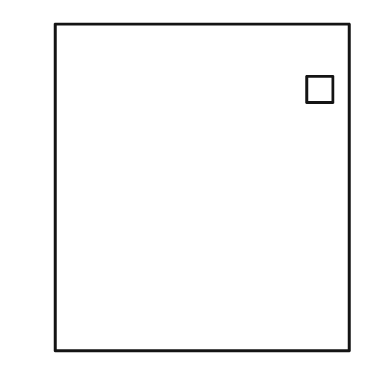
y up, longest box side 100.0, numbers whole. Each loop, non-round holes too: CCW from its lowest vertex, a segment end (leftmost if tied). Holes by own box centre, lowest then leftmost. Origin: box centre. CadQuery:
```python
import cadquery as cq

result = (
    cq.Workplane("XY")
    .moveTo(-45.0, -50.0)
    .lineTo(45.0, -50.0)
    .lineTo(45.0, 50.0)
    .lineTo(-45.0, 50.0)
    .close()
    .moveTo(32.0, 26.0)
    .lineTo(40.0, 26.0)
    .lineTo(40.0, 34.0)
    .lineTo(32.0, 34.0)
    .close()
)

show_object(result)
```